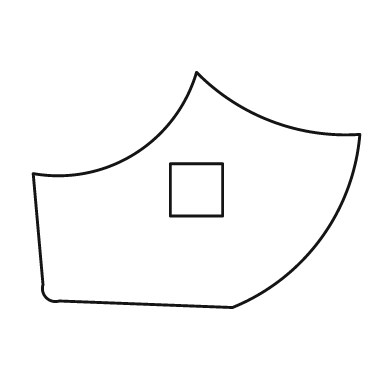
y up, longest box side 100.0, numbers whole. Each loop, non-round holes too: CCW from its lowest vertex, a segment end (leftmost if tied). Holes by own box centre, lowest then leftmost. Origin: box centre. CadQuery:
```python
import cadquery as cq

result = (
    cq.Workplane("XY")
    .moveTo(11.0, -36.0)
    .threePointArc((38.0, -15.0), (50.0, 17.0))
    .threePointArc((23.0, 21.0), (0.0, 36.0))
    .threePointArc((-19.0, 11.0), (-50.0, 5.0))
    .lineTo(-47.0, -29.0)
    .threePointArc((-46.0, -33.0), (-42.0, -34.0))
    .close()
    .moveTo(-8.0, -8.0)
    .lineTo(8.0, -8.0)
    .lineTo(8.0, 8.0)
    .lineTo(-8.0, 8.0)
    .close()
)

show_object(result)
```